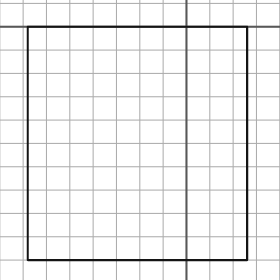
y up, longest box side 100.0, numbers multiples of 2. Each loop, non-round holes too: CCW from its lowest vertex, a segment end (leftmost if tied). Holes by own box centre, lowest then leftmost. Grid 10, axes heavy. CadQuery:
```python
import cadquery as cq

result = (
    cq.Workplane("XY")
    .moveTo(-68.0, -100.0)
    .lineTo(26.0, -100.0)
    .lineTo(26.0, 0.0)
    .lineTo(-68.0, 0.0)
    .close()
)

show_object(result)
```